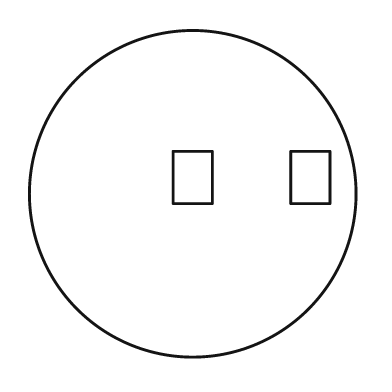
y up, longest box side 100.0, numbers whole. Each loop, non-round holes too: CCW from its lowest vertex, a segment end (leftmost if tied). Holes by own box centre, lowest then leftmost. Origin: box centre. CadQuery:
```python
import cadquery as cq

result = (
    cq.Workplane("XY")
    .moveTo(0.0, 0.0)
    .circle(50.0)
    .moveTo(-6.0, -3.0)
    .lineTo(6.0, -3.0)
    .lineTo(6.0, 13.0)
    .lineTo(-6.0, 13.0)
    .close()
    .moveTo(30.0, -3.0)
    .lineTo(42.0, -3.0)
    .lineTo(42.0, 13.0)
    .lineTo(30.0, 13.0)
    .close()
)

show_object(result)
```